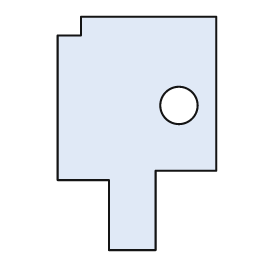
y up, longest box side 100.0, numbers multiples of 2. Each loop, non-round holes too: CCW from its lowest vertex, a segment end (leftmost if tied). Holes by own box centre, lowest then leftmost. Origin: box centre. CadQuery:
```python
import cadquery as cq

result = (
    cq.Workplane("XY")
    .moveTo(-12.0, -50.0)
    .lineTo(8.0, -50.0)
    .lineTo(8.0, -16.0)
    .lineTo(34.0, -16.0)
    .lineTo(34.0, 50.0)
    .lineTo(-24.0, 50.0)
    .lineTo(-24.0, 42.0)
    .lineTo(-34.0, 42.0)
    .lineTo(-34.0, -20.0)
    .lineTo(-12.0, -20.0)
    .close()
    .moveTo(18.0, 12.0)
    .circle(8.0)
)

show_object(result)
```